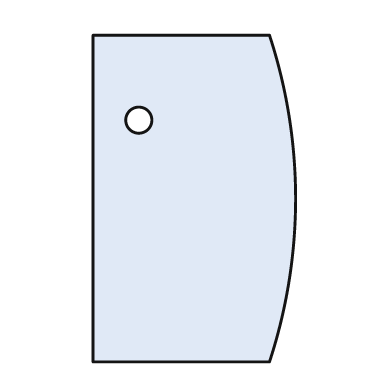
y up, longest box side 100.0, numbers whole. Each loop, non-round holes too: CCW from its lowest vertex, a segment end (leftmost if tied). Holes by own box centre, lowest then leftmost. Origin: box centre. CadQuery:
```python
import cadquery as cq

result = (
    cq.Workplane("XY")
    .moveTo(-31.0, -50.0)
    .lineTo(23.0, -50.0)
    .threePointArc((31.0, 0.0), (23.0, 50.0))
    .lineTo(-31.0, 50.0)
    .close()
    .moveTo(-17.0, 24.0)
    .circle(4.0)
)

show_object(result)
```